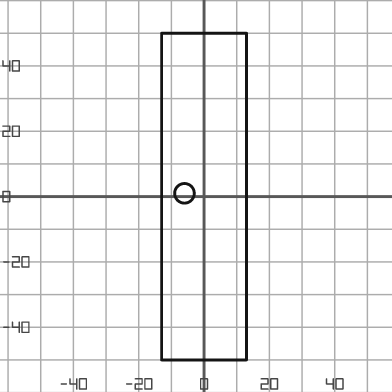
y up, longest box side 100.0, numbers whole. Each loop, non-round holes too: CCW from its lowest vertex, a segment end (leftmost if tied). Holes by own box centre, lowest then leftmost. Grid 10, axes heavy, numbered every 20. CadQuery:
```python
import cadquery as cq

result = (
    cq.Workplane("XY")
    .moveTo(-13.0, -50.0)
    .lineTo(13.0, -50.0)
    .lineTo(13.0, 50.0)
    .lineTo(-13.0, 50.0)
    .close()
    .moveTo(-6.0, 1.0)
    .circle(3.0)
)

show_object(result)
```